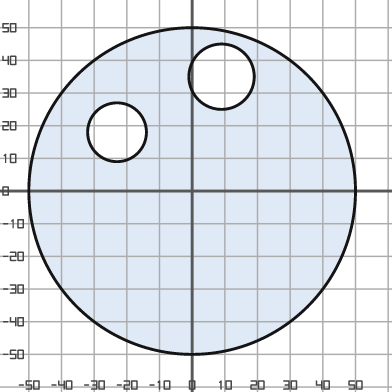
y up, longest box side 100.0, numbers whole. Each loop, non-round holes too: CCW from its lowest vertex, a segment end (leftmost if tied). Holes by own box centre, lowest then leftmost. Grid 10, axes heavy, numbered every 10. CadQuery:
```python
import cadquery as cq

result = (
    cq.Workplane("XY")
    .moveTo(0.0, 0.0)
    .circle(50.0)
    .moveTo(-23.0, 18.0)
    .circle(9.0)
    .moveTo(9.0, 35.0)
    .circle(10.0)
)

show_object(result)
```